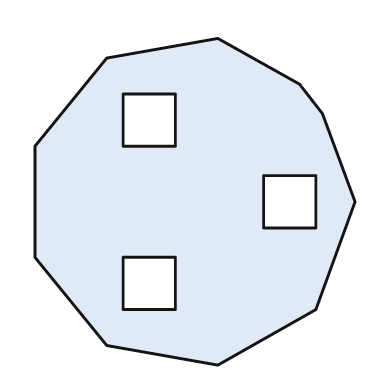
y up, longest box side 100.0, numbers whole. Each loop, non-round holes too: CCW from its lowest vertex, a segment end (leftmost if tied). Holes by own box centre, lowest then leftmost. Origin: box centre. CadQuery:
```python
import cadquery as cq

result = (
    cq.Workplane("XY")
    .moveTo(7.0, -50.0)
    .lineTo(37.0, -33.0)
    .lineTo(49.0, 0.0)
    .lineTo(39.0, 27.0)
    .lineTo(32.0, 36.0)
    .lineTo(7.0, 50.0)
    .lineTo(-27.0, 44.0)
    .lineTo(-49.0, 17.0)
    .lineTo(-49.0, -17.0)
    .lineTo(-27.0, -44.0)
    .close()
    .moveTo(-22.0, -33.0)
    .lineTo(-6.0, -33.0)
    .lineTo(-6.0, -17.0)
    .lineTo(-22.0, -17.0)
    .close()
    .moveTo(21.0, -8.0)
    .lineTo(37.0, -8.0)
    .lineTo(37.0, 8.0)
    .lineTo(21.0, 8.0)
    .close()
    .moveTo(-22.0, 17.0)
    .lineTo(-6.0, 17.0)
    .lineTo(-6.0, 33.0)
    .lineTo(-22.0, 33.0)
    .close()
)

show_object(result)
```